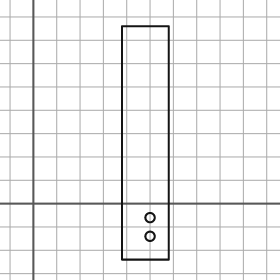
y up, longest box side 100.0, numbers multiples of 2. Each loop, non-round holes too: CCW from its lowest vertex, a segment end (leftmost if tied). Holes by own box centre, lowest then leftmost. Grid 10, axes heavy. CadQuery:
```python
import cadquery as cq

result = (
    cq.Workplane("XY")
    .moveTo(38.0, -24.0)
    .lineTo(58.0, -24.0)
    .lineTo(58.0, 76.0)
    .lineTo(38.0, 76.0)
    .close()
    .moveTo(50.0, -14.0)
    .circle(2.0)
    .moveTo(50.0, -6.0)
    .circle(2.0)
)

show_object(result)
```